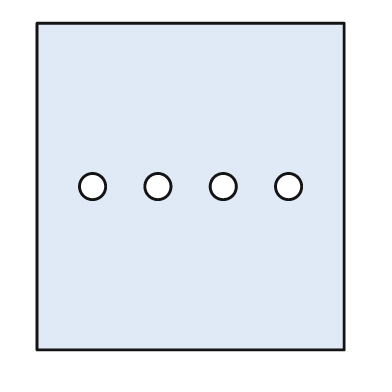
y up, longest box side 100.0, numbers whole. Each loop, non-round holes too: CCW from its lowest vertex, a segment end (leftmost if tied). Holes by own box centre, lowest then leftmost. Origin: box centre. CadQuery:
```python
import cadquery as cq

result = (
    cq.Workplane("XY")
    .moveTo(-47.0, -50.0)
    .lineTo(47.0, -50.0)
    .lineTo(47.0, 50.0)
    .lineTo(-47.0, 50.0)
    .close()
    .moveTo(-30.0, 0.0)
    .circle(4.0)
    .moveTo(-10.0, 0.0)
    .circle(4.0)
    .moveTo(10.0, 0.0)
    .circle(4.0)
    .moveTo(30.0, 0.0)
    .circle(4.0)
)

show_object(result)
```